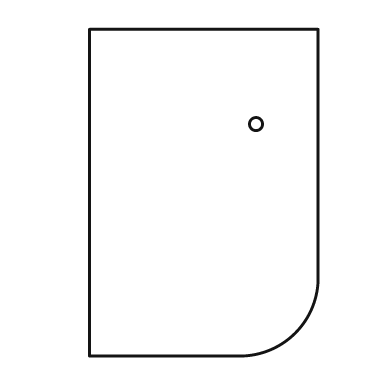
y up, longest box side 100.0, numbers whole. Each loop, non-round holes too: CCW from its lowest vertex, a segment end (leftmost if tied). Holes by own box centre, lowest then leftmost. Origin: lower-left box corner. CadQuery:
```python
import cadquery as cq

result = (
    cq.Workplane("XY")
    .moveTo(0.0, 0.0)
    .lineTo(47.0, 0.0)
    .threePointArc((63.0, 7.0), (70.0, 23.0))
    .lineTo(70.0, 100.0)
    .lineTo(0.0, 100.0)
    .close()
    .moveTo(51.0, 71.0)
    .circle(2.0)
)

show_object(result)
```